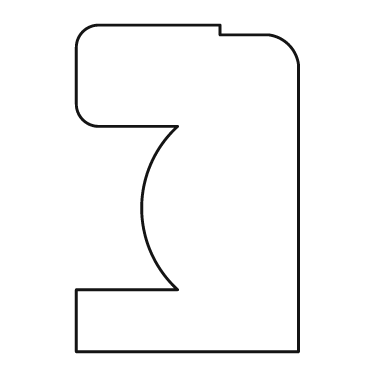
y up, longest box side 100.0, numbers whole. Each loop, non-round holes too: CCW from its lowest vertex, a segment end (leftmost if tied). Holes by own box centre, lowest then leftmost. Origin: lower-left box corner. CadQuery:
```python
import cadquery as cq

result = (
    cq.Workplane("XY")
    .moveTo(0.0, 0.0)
    .lineTo(68.0, 0.0)
    .lineTo(68.0, 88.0)
    .threePointArc((65.0, 94.0), (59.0, 97.0))
    .lineTo(44.0, 97.0)
    .lineTo(44.0, 100.0)
    .lineTo(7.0, 100.0)
    .threePointArc((2.0, 98.0), (0.0, 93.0))
    .lineTo(0.0, 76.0)
    .threePointArc((2.0, 71.0), (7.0, 69.0))
    .lineTo(31.0, 69.0)
    .threePointArc((20.0, 44.0), (31.0, 19.0))
    .lineTo(0.0, 19.0)
    .close()
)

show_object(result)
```